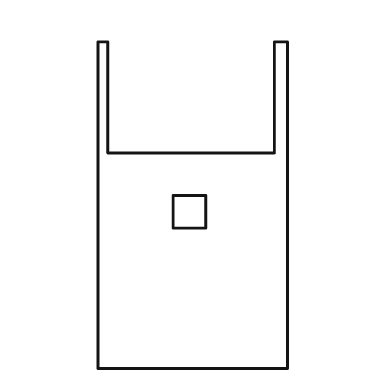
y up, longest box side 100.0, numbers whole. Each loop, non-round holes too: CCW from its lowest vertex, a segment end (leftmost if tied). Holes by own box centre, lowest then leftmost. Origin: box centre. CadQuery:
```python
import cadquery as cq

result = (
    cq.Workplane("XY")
    .moveTo(-29.0, -50.0)
    .lineTo(29.0, -50.0)
    .lineTo(29.0, 50.0)
    .lineTo(25.0, 50.0)
    .lineTo(25.0, 16.0)
    .lineTo(-26.0, 16.0)
    .lineTo(-26.0, 50.0)
    .lineTo(-29.0, 50.0)
    .close()
    .moveTo(-6.0, -7.0)
    .lineTo(4.0, -7.0)
    .lineTo(4.0, 3.0)
    .lineTo(-6.0, 3.0)
    .close()
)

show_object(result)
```